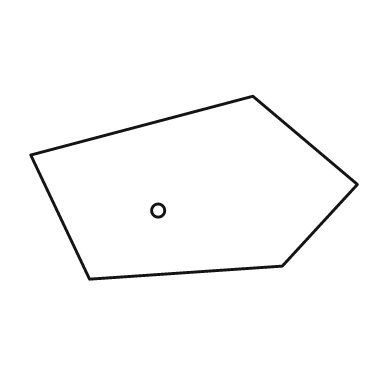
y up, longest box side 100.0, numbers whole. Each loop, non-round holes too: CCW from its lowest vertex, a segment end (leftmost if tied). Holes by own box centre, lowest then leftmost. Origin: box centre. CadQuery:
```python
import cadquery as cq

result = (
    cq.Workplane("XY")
    .moveTo(-32.0, -28.0)
    .lineTo(27.0, -24.0)
    .lineTo(50.0, 1.0)
    .lineTo(18.0, 28.0)
    .lineTo(-50.0, 10.0)
    .close()
    .moveTo(-11.0, -7.0)
    .circle(2.0)
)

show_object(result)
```